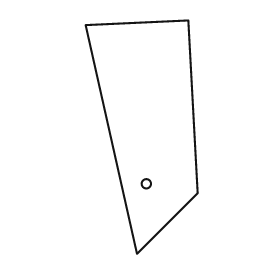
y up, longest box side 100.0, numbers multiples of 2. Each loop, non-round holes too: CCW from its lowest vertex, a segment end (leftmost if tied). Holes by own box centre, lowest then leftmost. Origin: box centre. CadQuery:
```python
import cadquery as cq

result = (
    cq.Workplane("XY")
    .moveTo(-2.0, -50.0)
    .lineTo(24.0, -24.0)
    .lineTo(20.0, 50.0)
    .lineTo(-24.0, 48.0)
    .close()
    .moveTo(2.0, -20.0)
    .circle(2.0)
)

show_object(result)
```